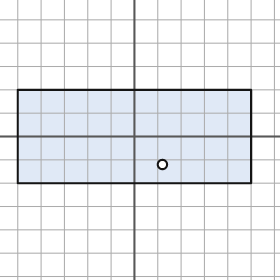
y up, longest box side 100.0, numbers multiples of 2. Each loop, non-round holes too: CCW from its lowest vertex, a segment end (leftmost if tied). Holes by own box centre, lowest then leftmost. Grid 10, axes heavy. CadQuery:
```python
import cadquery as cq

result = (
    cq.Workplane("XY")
    .moveTo(-50.0, -20.0)
    .lineTo(50.0, -20.0)
    .lineTo(50.0, 20.0)
    .lineTo(-50.0, 20.0)
    .close()
    .moveTo(12.0, -12.0)
    .circle(2.0)
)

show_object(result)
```